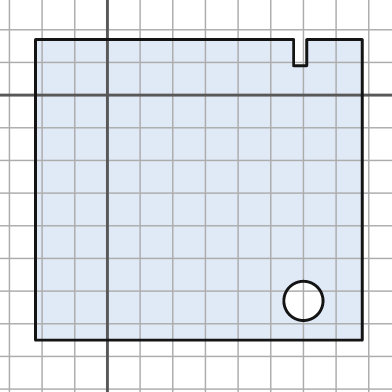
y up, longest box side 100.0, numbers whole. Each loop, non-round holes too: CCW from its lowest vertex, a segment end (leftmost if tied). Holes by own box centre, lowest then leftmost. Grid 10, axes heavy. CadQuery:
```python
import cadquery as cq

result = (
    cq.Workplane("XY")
    .moveTo(-22.0, -75.0)
    .lineTo(78.0, -75.0)
    .lineTo(78.0, 17.0)
    .lineTo(61.0, 17.0)
    .lineTo(61.0, 9.0)
    .lineTo(57.0, 9.0)
    .lineTo(57.0, 17.0)
    .lineTo(-22.0, 17.0)
    .close()
    .moveTo(60.0, -63.0)
    .circle(6.0)
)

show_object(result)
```